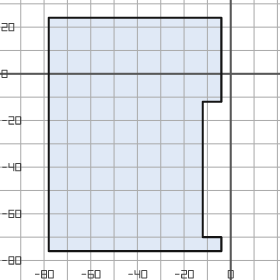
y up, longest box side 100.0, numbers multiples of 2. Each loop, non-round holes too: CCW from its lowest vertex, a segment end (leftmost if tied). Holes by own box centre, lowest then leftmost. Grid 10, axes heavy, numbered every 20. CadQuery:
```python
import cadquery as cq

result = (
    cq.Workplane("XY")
    .moveTo(-78.0, -76.0)
    .lineTo(-4.0, -76.0)
    .lineTo(-4.0, -70.0)
    .lineTo(-12.0, -70.0)
    .lineTo(-12.0, -12.0)
    .lineTo(-4.0, -12.0)
    .lineTo(-4.0, 24.0)
    .lineTo(-78.0, 24.0)
    .close()
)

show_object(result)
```